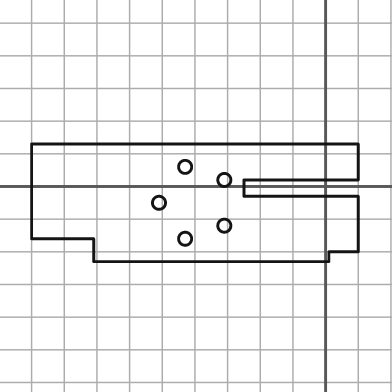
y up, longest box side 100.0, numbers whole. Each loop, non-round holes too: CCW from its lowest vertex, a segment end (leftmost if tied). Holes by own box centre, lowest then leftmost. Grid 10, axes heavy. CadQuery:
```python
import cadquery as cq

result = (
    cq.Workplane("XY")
    .moveTo(-71.0, -23.0)
    .lineTo(1.0, -23.0)
    .lineTo(1.0, -20.0)
    .lineTo(10.0, -20.0)
    .lineTo(10.0, -3.0)
    .lineTo(-25.0, -3.0)
    .lineTo(-25.0, 2.0)
    .lineTo(10.0, 2.0)
    .lineTo(10.0, 13.0)
    .lineTo(-90.0, 13.0)
    .lineTo(-90.0, -16.0)
    .lineTo(-71.0, -16.0)
    .close()
    .moveTo(-43.0, -16.0)
    .circle(2.0)
    .moveTo(-31.0, -12.0)
    .circle(2.0)
    .moveTo(-51.0, -5.0)
    .circle(2.0)
    .moveTo(-31.0, 2.0)
    .circle(2.0)
    .moveTo(-43.0, 6.0)
    .circle(2.0)
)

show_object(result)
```